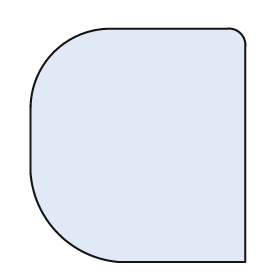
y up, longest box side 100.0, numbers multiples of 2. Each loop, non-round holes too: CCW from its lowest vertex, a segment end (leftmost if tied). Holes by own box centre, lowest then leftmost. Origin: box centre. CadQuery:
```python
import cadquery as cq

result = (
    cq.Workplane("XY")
    .moveTo(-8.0, -50.0)
    .lineTo(46.0, -50.0)
    .lineTo(46.0, 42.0)
    .threePointArc((44.0, 48.0), (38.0, 50.0))
    .lineTo(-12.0, 50.0)
    .threePointArc((-36.0, 40.0), (-46.0, 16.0))
    .lineTo(-46.0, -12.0)
    .threePointArc((-34.0, -38.0), (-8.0, -50.0))
    .close()
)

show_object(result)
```